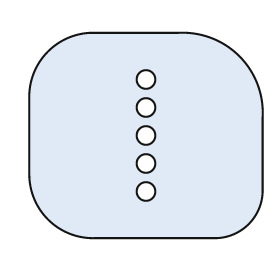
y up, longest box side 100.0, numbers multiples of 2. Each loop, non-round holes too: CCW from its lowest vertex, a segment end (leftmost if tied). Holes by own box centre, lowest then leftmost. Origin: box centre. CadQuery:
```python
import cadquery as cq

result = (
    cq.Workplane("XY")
    .moveTo(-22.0, -44.0)
    .lineTo(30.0, -44.0)
    .threePointArc((44.0, -38.0), (50.0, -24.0))
    .lineTo(50.0, 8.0)
    .threePointArc((40.0, 34.0), (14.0, 44.0))
    .lineTo(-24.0, 44.0)
    .threePointArc((-42.0, 36.0), (-50.0, 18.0))
    .lineTo(-50.0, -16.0)
    .threePointArc((-42.0, -36.0), (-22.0, -44.0))
    .close()
    .moveTo(0.0, -24.0)
    .circle(4.0)
    .moveTo(0.0, -12.0)
    .circle(4.0)
    .moveTo(0.0, 0.0)
    .circle(4.0)
    .moveTo(0.0, 12.0)
    .circle(4.0)
    .moveTo(0.0, 24.0)
    .circle(4.0)
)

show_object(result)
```